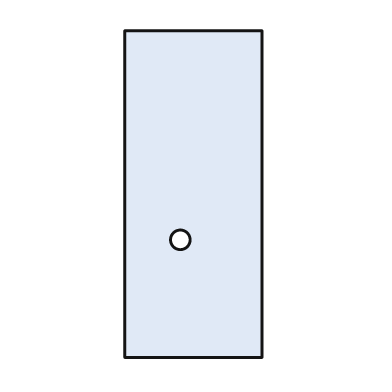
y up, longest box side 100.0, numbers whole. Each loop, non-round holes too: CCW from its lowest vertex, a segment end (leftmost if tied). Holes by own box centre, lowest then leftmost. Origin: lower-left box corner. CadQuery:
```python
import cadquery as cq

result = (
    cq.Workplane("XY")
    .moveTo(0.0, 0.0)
    .lineTo(42.0, 0.0)
    .lineTo(42.0, 100.0)
    .lineTo(0.0, 100.0)
    .close()
    .moveTo(17.0, 36.0)
    .circle(3.0)
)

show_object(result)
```